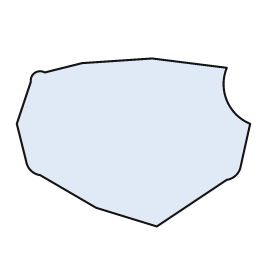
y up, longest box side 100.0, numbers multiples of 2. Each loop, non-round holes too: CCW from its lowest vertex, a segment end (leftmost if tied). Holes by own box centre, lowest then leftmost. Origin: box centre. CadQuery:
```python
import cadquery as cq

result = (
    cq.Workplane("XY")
    .moveTo(10.0, -36.0)
    .lineTo(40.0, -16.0)
    .threePointArc((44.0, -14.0), (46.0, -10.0))
    .lineTo(50.0, 8.0)
    .threePointArc((40.0, 18.0), (40.0, 32.0))
    .lineTo(8.0, 36.0)
    .lineTo(-22.0, 34.0)
    .lineTo(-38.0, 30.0)
    .threePointArc((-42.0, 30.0), (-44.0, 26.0))
    .lineTo(-50.0, 8.0)
    .lineTo(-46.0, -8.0)
    .threePointArc((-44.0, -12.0), (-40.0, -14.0))
    .lineTo(-16.0, -28.0)
    .close()
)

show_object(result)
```